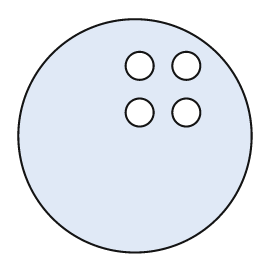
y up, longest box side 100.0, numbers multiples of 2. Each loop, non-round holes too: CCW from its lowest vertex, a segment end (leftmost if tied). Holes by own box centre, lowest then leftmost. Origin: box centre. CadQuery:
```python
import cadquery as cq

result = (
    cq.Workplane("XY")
    .moveTo(0.0, 0.0)
    .circle(50.0)
    .moveTo(2.0, 10.0)
    .circle(6.0)
    .moveTo(22.0, 10.0)
    .circle(6.0)
    .moveTo(2.0, 30.0)
    .circle(6.0)
    .moveTo(22.0, 30.0)
    .circle(6.0)
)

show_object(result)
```